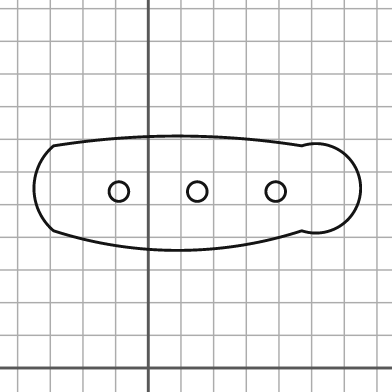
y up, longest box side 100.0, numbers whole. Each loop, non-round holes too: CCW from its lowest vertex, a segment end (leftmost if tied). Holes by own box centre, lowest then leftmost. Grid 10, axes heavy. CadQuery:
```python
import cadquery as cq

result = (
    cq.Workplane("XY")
    .moveTo(-29.0, 42.0)
    .threePointArc((9.0, 36.0), (47.0, 42.0))
    .threePointArc((65.0, 55.0), (47.0, 68.0))
    .threePointArc((9.0, 71.0), (-29.0, 68.0))
    .threePointArc((-35.0, 55.0), (-29.0, 42.0))
    .close()
    .moveTo(-9.0, 54.0)
    .circle(3.0)
    .moveTo(15.0, 54.0)
    .circle(3.0)
    .moveTo(39.0, 54.0)
    .circle(3.0)
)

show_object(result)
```